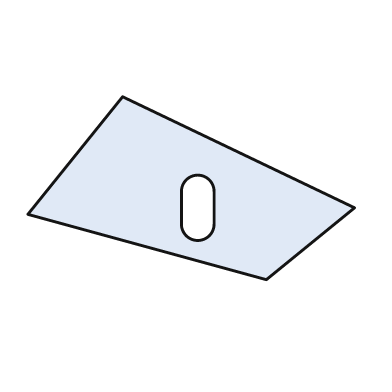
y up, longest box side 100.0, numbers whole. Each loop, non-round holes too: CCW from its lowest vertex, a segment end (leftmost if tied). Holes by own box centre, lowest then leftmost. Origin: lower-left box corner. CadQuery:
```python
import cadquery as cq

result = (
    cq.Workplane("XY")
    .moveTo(73.0, 0.0)
    .lineTo(100.0, 22.0)
    .lineTo(29.0, 56.0)
    .lineTo(0.0, 20.0)
    .close()
    .moveTo(47.0, 17.0)
    .threePointArc((52.0, 12.0), (57.0, 17.0))
    .lineTo(57.0, 27.0)
    .threePointArc((52.0, 32.0), (47.0, 27.0))
    .close()
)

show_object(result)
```